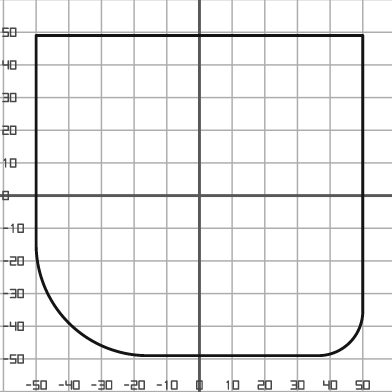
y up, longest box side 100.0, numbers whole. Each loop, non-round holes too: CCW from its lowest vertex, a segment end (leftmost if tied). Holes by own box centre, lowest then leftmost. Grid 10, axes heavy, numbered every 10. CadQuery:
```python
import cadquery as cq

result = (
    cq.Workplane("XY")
    .moveTo(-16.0, -49.0)
    .lineTo(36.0, -49.0)
    .threePointArc((46.0, -45.0), (50.0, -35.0))
    .lineTo(50.0, 49.0)
    .lineTo(-50.0, 49.0)
    .lineTo(-50.0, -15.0)
    .threePointArc((-40.0, -39.0), (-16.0, -49.0))
    .close()
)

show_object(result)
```